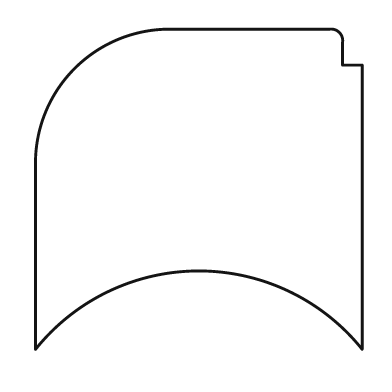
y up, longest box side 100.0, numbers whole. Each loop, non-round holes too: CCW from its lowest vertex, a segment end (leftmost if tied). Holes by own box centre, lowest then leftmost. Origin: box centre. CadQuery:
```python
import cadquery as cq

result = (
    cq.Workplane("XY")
    .moveTo(-50.0, -49.0)
    .threePointArc((0.0, -25.0), (50.0, -49.0))
    .lineTo(50.0, 38.0)
    .lineTo(44.0, 38.0)
    .lineTo(44.0, 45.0)
    .threePointArc((43.0, 48.0), (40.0, 49.0))
    .lineTo(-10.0, 49.0)
    .threePointArc((-38.0, 37.0), (-50.0, 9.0))
    .close()
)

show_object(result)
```